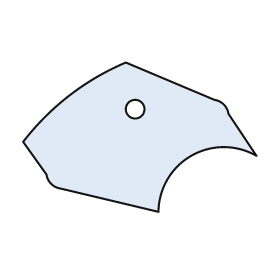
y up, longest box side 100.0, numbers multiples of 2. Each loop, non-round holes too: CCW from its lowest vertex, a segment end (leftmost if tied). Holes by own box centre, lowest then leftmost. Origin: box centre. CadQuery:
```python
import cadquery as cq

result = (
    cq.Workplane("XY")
    .moveTo(8.0, -32.0)
    .threePointArc((22.0, -8.0), (50.0, -8.0))
    .lineTo(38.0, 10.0)
    .threePointArc((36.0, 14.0), (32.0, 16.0))
    .lineTo(-6.0, 32.0)
    .threePointArc((-30.0, 18.0), (-50.0, -2.0))
    .lineTo(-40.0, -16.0)
    .threePointArc((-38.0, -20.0), (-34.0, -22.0))
    .close()
    .moveTo(-2.0, 12.0)
    .circle(4.0)
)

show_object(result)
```